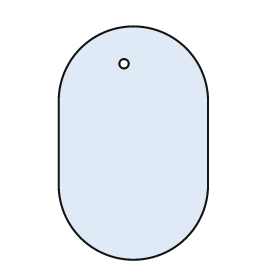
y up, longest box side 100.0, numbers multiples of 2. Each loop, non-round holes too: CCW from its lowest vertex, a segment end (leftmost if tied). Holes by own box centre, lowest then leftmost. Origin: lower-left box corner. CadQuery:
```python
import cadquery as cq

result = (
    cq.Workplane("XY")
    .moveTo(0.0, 32.0)
    .threePointArc((32.0, 0.0), (64.0, 32.0))
    .lineTo(64.0, 68.0)
    .threePointArc((32.0, 100.0), (0.0, 68.0))
    .close()
    .moveTo(28.0, 84.0)
    .circle(2.0)
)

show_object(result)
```